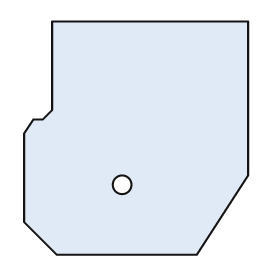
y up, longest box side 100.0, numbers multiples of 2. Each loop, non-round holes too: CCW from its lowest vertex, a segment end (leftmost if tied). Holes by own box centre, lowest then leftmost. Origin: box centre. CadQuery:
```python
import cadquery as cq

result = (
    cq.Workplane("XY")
    .moveTo(-34.0, -50.0)
    .lineTo(26.0, -50.0)
    .lineTo(48.0, -16.0)
    .lineTo(48.0, 50.0)
    .lineTo(-36.0, 50.0)
    .lineTo(-36.0, 12.0)
    .lineTo(-40.0, 8.0)
    .lineTo(-44.0, 8.0)
    .lineTo(-48.0, 2.0)
    .lineTo(-48.0, -36.0)
    .close()
    .moveTo(-6.0, -20.0)
    .circle(4.0)
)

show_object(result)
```